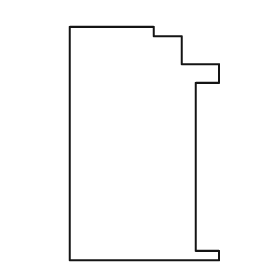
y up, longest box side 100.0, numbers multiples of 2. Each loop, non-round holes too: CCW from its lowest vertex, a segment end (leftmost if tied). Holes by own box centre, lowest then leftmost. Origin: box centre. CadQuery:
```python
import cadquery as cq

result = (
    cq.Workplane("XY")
    .moveTo(-32.0, -50.0)
    .lineTo(32.0, -50.0)
    .lineTo(32.0, -46.0)
    .lineTo(22.0, -46.0)
    .lineTo(22.0, 26.0)
    .lineTo(32.0, 26.0)
    .lineTo(32.0, 34.0)
    .lineTo(16.0, 34.0)
    .lineTo(16.0, 46.0)
    .lineTo(4.0, 46.0)
    .lineTo(4.0, 50.0)
    .lineTo(-32.0, 50.0)
    .close()
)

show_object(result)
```